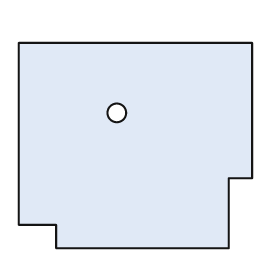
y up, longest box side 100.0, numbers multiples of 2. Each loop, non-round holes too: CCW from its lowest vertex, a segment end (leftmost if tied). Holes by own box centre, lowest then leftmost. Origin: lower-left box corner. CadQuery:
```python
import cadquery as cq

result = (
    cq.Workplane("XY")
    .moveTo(16.0, 0.0)
    .lineTo(90.0, 0.0)
    .lineTo(90.0, 30.0)
    .lineTo(100.0, 30.0)
    .lineTo(100.0, 88.0)
    .lineTo(0.0, 88.0)
    .lineTo(0.0, 10.0)
    .lineTo(16.0, 10.0)
    .close()
    .moveTo(42.0, 58.0)
    .circle(4.0)
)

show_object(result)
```